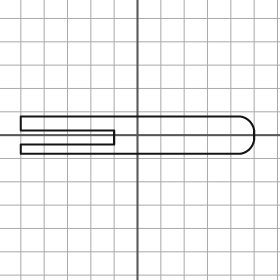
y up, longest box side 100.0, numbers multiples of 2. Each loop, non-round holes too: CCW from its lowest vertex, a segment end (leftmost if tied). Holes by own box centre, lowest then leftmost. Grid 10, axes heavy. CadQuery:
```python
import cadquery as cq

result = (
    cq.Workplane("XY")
    .moveTo(-50.0, -8.0)
    .lineTo(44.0, -8.0)
    .threePointArc((48.0, -6.0), (50.0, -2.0))
    .lineTo(50.0, 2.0)
    .threePointArc((48.0, 6.0), (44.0, 8.0))
    .lineTo(-50.0, 8.0)
    .lineTo(-50.0, 2.0)
    .lineTo(-10.0, 2.0)
    .lineTo(-10.0, -4.0)
    .lineTo(-50.0, -4.0)
    .close()
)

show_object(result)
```